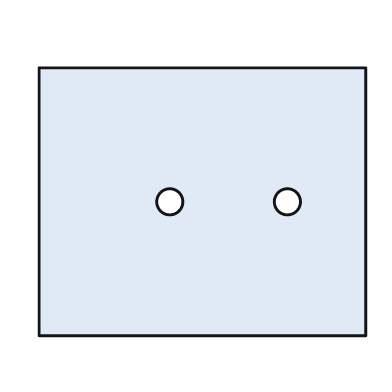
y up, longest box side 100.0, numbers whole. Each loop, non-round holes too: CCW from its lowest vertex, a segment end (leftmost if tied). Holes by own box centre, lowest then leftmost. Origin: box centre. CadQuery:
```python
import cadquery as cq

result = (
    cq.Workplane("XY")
    .moveTo(-50.0, -41.0)
    .lineTo(50.0, -41.0)
    .lineTo(50.0, 41.0)
    .lineTo(-50.0, 41.0)
    .close()
    .moveTo(-10.0, 0.0)
    .circle(4.0)
    .moveTo(26.0, 0.0)
    .circle(4.0)
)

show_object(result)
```